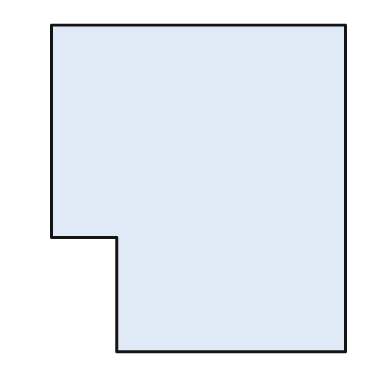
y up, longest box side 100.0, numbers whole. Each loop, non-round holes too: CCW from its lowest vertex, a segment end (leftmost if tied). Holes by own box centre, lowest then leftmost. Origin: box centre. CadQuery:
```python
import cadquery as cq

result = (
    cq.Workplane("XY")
    .moveTo(-25.0, -50.0)
    .lineTo(45.0, -50.0)
    .lineTo(45.0, 50.0)
    .lineTo(-45.0, 50.0)
    .lineTo(-45.0, -15.0)
    .lineTo(-25.0, -15.0)
    .close()
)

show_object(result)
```